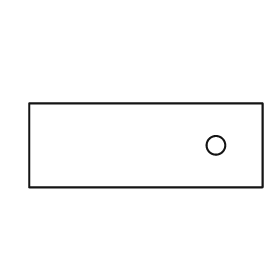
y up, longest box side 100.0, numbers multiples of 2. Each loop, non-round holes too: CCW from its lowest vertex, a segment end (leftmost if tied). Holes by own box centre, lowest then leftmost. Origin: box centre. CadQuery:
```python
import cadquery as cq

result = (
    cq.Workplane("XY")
    .moveTo(-50.0, -18.0)
    .lineTo(50.0, -18.0)
    .lineTo(50.0, 18.0)
    .lineTo(-50.0, 18.0)
    .close()
    .moveTo(30.0, 0.0)
    .circle(4.0)
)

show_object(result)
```